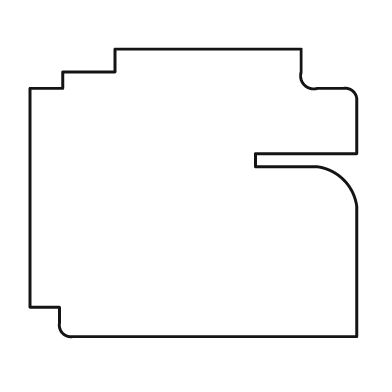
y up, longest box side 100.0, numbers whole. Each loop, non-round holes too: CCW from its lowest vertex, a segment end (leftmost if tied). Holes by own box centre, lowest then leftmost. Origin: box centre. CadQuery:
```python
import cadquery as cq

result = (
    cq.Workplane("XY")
    .moveTo(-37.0, -44.0)
    .lineTo(50.0, -44.0)
    .lineTo(50.0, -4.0)
    .threePointArc((46.0, 4.0), (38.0, 8.0))
    .lineTo(19.0, 8.0)
    .lineTo(19.0, 12.0)
    .lineTo(50.0, 12.0)
    .lineTo(50.0, 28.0)
    .threePointArc((49.0, 31.0), (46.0, 32.0))
    .lineTo(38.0, 32.0)
    .threePointArc((34.0, 33.0), (33.0, 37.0))
    .lineTo(33.0, 44.0)
    .lineTo(-24.0, 44.0)
    .lineTo(-24.0, 37.0)
    .lineTo(-40.0, 37.0)
    .lineTo(-40.0, 32.0)
    .lineTo(-50.0, 32.0)
    .lineTo(-50.0, -35.0)
    .lineTo(-41.0, -35.0)
    .lineTo(-41.0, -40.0)
    .threePointArc((-40.0, -43.0), (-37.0, -44.0))
    .close()
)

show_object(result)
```